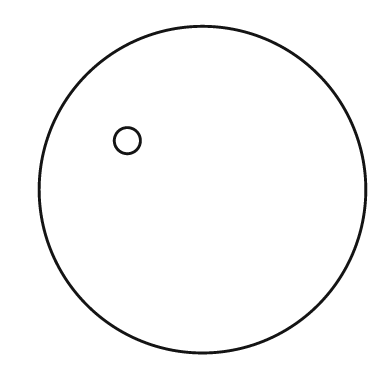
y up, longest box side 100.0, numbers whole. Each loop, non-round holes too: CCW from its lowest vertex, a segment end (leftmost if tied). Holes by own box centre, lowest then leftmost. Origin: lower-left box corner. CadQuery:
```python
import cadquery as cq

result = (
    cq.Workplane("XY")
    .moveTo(50.0, 50.0)
    .circle(50.0)
    .moveTo(27.0, 65.0)
    .circle(4.0)
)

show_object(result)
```